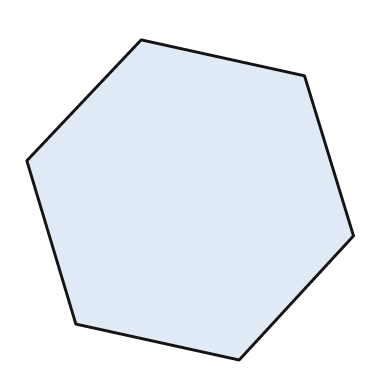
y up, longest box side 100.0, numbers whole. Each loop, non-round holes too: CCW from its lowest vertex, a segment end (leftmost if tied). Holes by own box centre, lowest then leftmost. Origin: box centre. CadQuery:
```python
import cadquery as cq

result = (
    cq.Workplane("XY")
    .moveTo(15.0, -49.0)
    .lineTo(50.0, -11.0)
    .lineTo(35.0, 38.0)
    .lineTo(-15.0, 49.0)
    .lineTo(-50.0, 12.0)
    .lineTo(-35.0, -38.0)
    .close()
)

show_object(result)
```